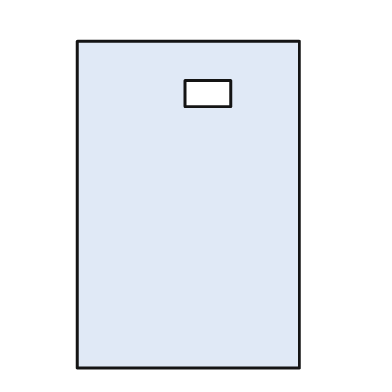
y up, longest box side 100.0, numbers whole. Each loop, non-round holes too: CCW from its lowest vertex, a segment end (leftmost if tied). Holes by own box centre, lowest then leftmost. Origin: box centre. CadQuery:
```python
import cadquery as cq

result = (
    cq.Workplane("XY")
    .moveTo(-34.0, -50.0)
    .lineTo(34.0, -50.0)
    .lineTo(34.0, 50.0)
    .lineTo(-34.0, 50.0)
    .close()
    .moveTo(-1.0, 30.0)
    .lineTo(13.0, 30.0)
    .lineTo(13.0, 38.0)
    .lineTo(-1.0, 38.0)
    .close()
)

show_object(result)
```